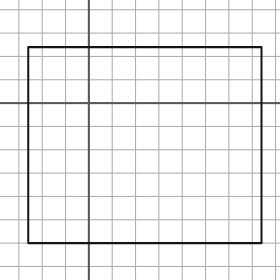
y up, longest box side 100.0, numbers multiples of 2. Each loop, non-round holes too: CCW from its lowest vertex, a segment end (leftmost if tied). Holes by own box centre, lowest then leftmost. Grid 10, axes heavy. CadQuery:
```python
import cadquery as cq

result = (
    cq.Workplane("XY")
    .moveTo(-26.0, -60.0)
    .lineTo(74.0, -60.0)
    .lineTo(74.0, 24.0)
    .lineTo(-26.0, 24.0)
    .close()
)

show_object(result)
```